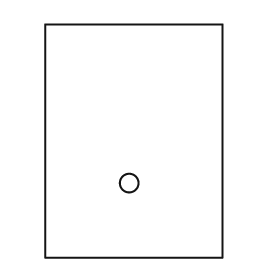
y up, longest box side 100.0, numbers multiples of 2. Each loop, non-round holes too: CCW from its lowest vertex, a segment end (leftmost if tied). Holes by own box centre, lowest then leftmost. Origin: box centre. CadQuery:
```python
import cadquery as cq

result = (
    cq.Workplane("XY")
    .moveTo(-38.0, -50.0)
    .lineTo(38.0, -50.0)
    .lineTo(38.0, 50.0)
    .lineTo(-38.0, 50.0)
    .close()
    .moveTo(-2.0, -18.0)
    .circle(4.0)
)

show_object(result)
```